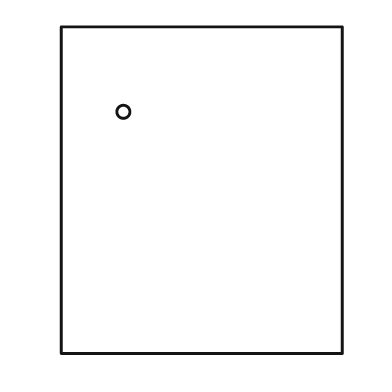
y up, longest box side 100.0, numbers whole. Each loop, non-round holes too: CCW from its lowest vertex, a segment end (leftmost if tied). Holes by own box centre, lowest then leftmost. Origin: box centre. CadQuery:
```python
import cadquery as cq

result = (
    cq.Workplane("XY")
    .moveTo(-43.0, -50.0)
    .lineTo(43.0, -50.0)
    .lineTo(43.0, 50.0)
    .lineTo(-43.0, 50.0)
    .close()
    .moveTo(-24.0, 24.0)
    .circle(2.0)
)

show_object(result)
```